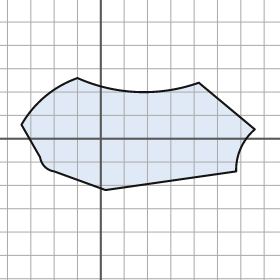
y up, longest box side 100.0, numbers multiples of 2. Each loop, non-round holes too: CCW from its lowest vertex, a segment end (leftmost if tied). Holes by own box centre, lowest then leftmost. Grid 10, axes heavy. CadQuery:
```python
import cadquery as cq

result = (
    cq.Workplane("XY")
    .moveTo(2.0, -22.0)
    .lineTo(58.0, -14.0)
    .threePointArc((60.0, -4.0), (66.0, 4.0))
    .lineTo(42.0, 24.0)
    .threePointArc((16.0, 20.0), (-10.0, 26.0))
    .threePointArc((-24.0, 18.0), (-34.0, 6.0))
    .lineTo(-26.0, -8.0)
    .threePointArc((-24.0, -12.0), (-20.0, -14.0))
    .close()
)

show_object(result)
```